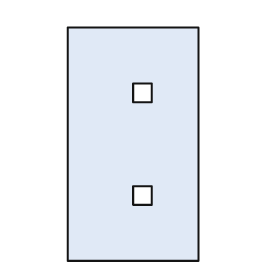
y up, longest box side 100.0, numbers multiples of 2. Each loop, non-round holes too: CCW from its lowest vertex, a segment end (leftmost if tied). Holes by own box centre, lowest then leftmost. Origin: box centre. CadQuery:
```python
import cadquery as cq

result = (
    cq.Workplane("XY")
    .moveTo(-28.0, -50.0)
    .lineTo(28.0, -50.0)
    .lineTo(28.0, 50.0)
    .lineTo(-28.0, 50.0)
    .close()
    .moveTo(0.0, -26.0)
    .lineTo(8.0, -26.0)
    .lineTo(8.0, -18.0)
    .lineTo(0.0, -18.0)
    .close()
    .moveTo(0.0, 18.0)
    .lineTo(8.0, 18.0)
    .lineTo(8.0, 26.0)
    .lineTo(0.0, 26.0)
    .close()
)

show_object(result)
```